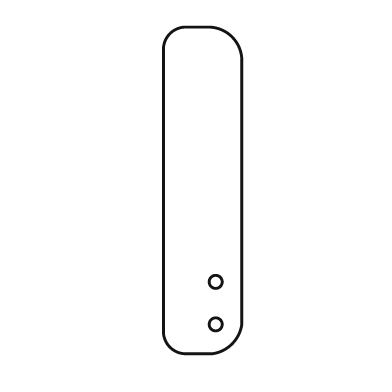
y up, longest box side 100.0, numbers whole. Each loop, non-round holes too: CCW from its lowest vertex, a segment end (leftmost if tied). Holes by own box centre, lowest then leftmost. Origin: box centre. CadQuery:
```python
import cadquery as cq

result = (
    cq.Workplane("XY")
    .moveTo(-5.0, -50.0)
    .lineTo(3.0, -50.0)
    .threePointArc((9.0, -47.0), (12.0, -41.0))
    .lineTo(12.0, 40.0)
    .threePointArc((9.0, 47.0), (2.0, 50.0))
    .lineTo(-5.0, 50.0)
    .threePointArc((-10.0, 48.0), (-12.0, 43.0))
    .lineTo(-12.0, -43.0)
    .threePointArc((-10.0, -48.0), (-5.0, -50.0))
    .close()
    .moveTo(4.0, -41.0)
    .circle(2.0)
    .moveTo(4.0, -28.0)
    .circle(2.0)
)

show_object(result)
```